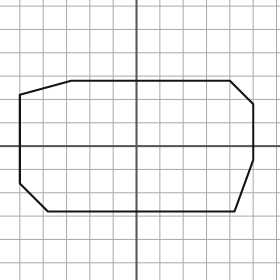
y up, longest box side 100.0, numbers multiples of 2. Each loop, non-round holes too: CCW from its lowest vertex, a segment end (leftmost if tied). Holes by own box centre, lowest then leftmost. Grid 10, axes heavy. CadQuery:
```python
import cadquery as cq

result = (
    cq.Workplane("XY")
    .moveTo(-38.0, -28.0)
    .lineTo(42.0, -28.0)
    .lineTo(50.0, -6.0)
    .lineTo(50.0, 18.0)
    .lineTo(40.0, 28.0)
    .lineTo(-28.0, 28.0)
    .lineTo(-50.0, 22.0)
    .lineTo(-50.0, -16.0)
    .close()
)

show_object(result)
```